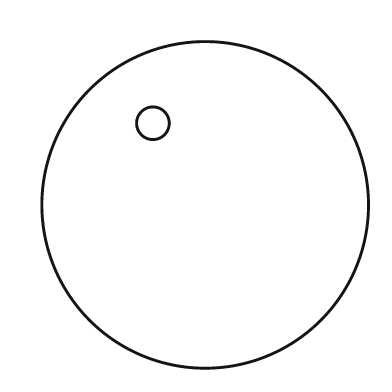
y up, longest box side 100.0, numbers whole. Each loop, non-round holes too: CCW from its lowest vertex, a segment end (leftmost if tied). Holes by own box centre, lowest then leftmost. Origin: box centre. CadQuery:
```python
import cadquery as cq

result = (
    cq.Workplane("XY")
    .moveTo(0.0, 0.0)
    .circle(50.0)
    .moveTo(-16.0, 25.0)
    .circle(5.0)
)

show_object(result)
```